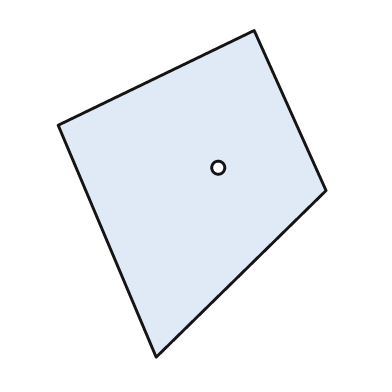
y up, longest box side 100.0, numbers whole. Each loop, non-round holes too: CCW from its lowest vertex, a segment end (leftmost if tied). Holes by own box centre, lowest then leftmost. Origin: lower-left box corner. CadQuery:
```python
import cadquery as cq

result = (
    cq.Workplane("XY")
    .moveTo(30.0, 0.0)
    .lineTo(82.0, 51.0)
    .lineTo(60.0, 100.0)
    .lineTo(0.0, 71.0)
    .close()
    .moveTo(49.0, 58.0)
    .circle(2.0)
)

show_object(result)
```